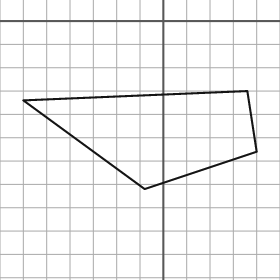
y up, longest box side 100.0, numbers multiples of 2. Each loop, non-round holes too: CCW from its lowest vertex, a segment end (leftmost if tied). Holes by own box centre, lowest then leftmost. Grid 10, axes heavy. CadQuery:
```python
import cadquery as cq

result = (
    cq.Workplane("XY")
    .moveTo(-8.0, -72.0)
    .lineTo(40.0, -56.0)
    .lineTo(36.0, -30.0)
    .lineTo(-60.0, -34.0)
    .close()
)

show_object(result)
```